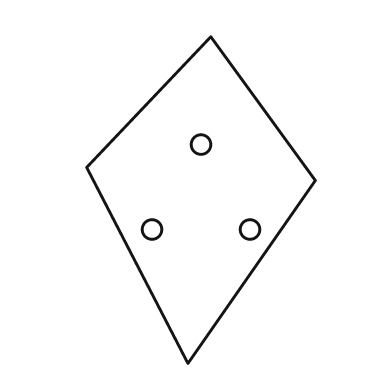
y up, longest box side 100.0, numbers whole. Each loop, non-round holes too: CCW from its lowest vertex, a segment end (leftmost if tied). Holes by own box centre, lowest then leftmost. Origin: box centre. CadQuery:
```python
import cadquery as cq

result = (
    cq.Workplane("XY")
    .moveTo(-4.0, -50.0)
    .lineTo(35.0, 6.0)
    .lineTo(3.0, 50.0)
    .lineTo(-35.0, 10.0)
    .close()
    .moveTo(-15.0, -9.0)
    .circle(3.0)
    .moveTo(15.0, -9.0)
    .circle(3.0)
    .moveTo(0.0, 17.0)
    .circle(3.0)
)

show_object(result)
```